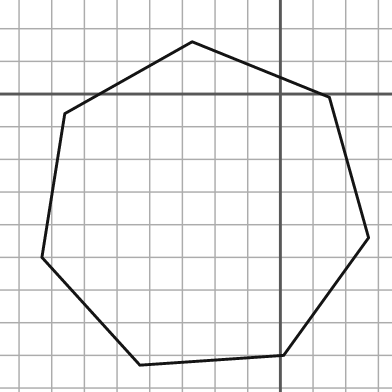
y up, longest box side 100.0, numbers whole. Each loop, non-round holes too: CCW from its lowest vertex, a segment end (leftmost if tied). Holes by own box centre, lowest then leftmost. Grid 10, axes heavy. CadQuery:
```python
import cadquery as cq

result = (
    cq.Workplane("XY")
    .moveTo(-43.0, -83.0)
    .lineTo(1.0, -80.0)
    .lineTo(27.0, -44.0)
    .lineTo(15.0, -1.0)
    .lineTo(-27.0, 16.0)
    .lineTo(-66.0, -6.0)
    .lineTo(-73.0, -50.0)
    .close()
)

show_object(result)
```